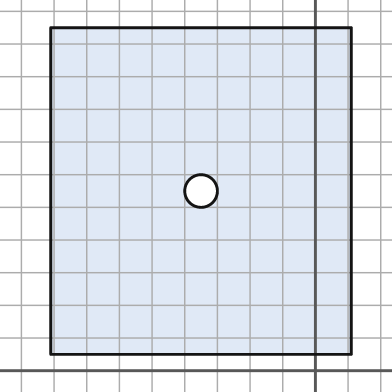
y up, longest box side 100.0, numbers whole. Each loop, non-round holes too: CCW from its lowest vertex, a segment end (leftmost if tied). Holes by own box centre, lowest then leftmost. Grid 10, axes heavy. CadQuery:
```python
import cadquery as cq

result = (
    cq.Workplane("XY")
    .moveTo(-81.0, 5.0)
    .lineTo(11.0, 5.0)
    .lineTo(11.0, 105.0)
    .lineTo(-81.0, 105.0)
    .close()
    .moveTo(-35.0, 55.0)
    .circle(5.0)
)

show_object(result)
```